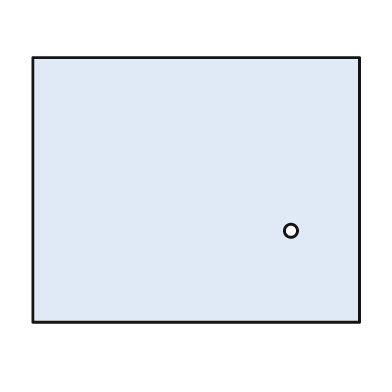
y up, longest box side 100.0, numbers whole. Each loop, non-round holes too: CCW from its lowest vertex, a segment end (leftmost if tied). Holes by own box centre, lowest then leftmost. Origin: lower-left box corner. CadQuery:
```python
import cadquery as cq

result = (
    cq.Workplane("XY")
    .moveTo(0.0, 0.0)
    .lineTo(100.0, 0.0)
    .lineTo(100.0, 81.0)
    .lineTo(0.0, 81.0)
    .close()
    .moveTo(79.0, 28.0)
    .circle(2.0)
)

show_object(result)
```